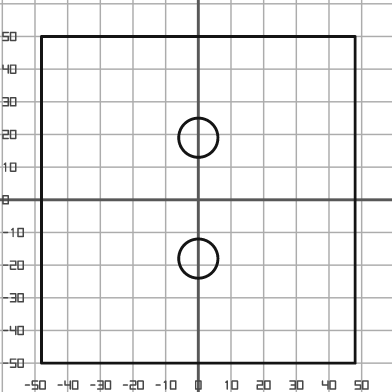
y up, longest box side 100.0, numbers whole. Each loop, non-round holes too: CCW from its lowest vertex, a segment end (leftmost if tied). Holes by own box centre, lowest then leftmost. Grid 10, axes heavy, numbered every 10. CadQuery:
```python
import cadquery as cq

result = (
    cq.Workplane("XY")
    .moveTo(-48.0, -50.0)
    .lineTo(48.0, -50.0)
    .lineTo(48.0, 50.0)
    .lineTo(-48.0, 50.0)
    .close()
    .moveTo(0.0, -18.0)
    .circle(6.0)
    .moveTo(0.0, 19.0)
    .circle(6.0)
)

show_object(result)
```